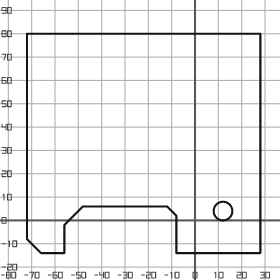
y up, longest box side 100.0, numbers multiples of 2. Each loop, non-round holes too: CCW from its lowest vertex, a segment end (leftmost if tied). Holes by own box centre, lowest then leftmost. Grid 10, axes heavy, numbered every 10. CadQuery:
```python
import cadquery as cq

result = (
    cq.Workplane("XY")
    .moveTo(-66.0, -14.0)
    .lineTo(-56.0, -14.0)
    .lineTo(-56.0, -2.0)
    .lineTo(-48.0, 6.0)
    .lineTo(-12.0, 6.0)
    .lineTo(-8.0, 2.0)
    .lineTo(-8.0, -14.0)
    .lineTo(28.0, -14.0)
    .lineTo(28.0, 80.0)
    .lineTo(-72.0, 80.0)
    .lineTo(-72.0, -8.0)
    .close()
    .moveTo(12.0, 4.0)
    .circle(4.0)
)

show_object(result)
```